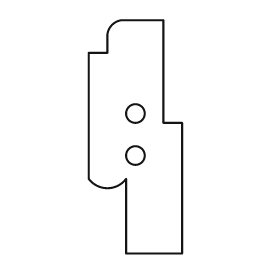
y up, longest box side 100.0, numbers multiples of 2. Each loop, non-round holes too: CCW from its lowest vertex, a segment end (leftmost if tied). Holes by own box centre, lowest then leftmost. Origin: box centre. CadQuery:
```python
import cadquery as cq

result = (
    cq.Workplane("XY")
    .moveTo(-4.0, -50.0)
    .lineTo(20.0, -50.0)
    .lineTo(20.0, 6.0)
    .lineTo(12.0, 6.0)
    .lineTo(12.0, 50.0)
    .lineTo(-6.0, 50.0)
    .threePointArc((-10.0, 48.0), (-12.0, 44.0))
    .lineTo(-12.0, 36.0)
    .lineTo(-20.0, 36.0)
    .lineTo(-20.0, -18.0)
    .threePointArc((-12.0, -22.0), (-4.0, -18.0))
    .close()
    .moveTo(0.0, -8.0)
    .circle(4.0)
    .moveTo(0.0, 10.0)
    .circle(4.0)
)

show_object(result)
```